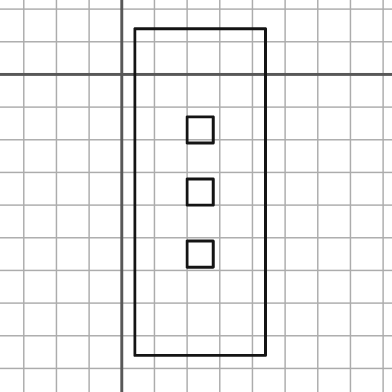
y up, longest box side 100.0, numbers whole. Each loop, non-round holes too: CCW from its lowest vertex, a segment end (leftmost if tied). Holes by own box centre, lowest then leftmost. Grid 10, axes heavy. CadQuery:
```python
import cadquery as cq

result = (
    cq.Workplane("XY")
    .moveTo(4.0, -86.0)
    .lineTo(44.0, -86.0)
    .lineTo(44.0, 14.0)
    .lineTo(4.0, 14.0)
    .close()
    .moveTo(20.0, -59.0)
    .lineTo(28.0, -59.0)
    .lineTo(28.0, -51.0)
    .lineTo(20.0, -51.0)
    .close()
    .moveTo(20.0, -40.0)
    .lineTo(28.0, -40.0)
    .lineTo(28.0, -32.0)
    .lineTo(20.0, -32.0)
    .close()
    .moveTo(20.0, -21.0)
    .lineTo(28.0, -21.0)
    .lineTo(28.0, -13.0)
    .lineTo(20.0, -13.0)
    .close()
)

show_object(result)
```